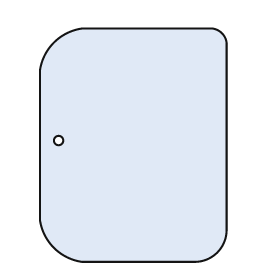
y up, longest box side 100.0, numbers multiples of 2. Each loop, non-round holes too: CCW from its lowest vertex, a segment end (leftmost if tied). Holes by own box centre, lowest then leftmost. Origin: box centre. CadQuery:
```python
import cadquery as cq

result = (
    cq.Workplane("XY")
    .moveTo(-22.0, -50.0)
    .lineTo(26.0, -50.0)
    .threePointArc((36.0, -46.0), (40.0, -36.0))
    .lineTo(40.0, 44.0)
    .threePointArc((38.0, 48.0), (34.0, 50.0))
    .lineTo(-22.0, 50.0)
    .threePointArc((-34.0, 44.0), (-40.0, 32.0))
    .lineTo(-40.0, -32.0)
    .threePointArc((-34.0, -44.0), (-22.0, -50.0))
    .close()
    .moveTo(-32.0, 2.0)
    .circle(2.0)
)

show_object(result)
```